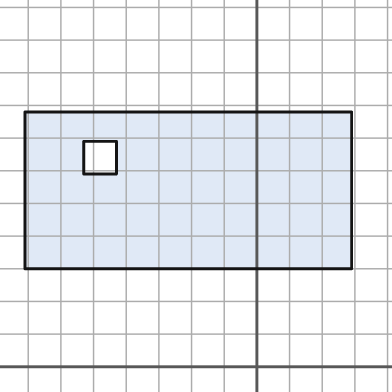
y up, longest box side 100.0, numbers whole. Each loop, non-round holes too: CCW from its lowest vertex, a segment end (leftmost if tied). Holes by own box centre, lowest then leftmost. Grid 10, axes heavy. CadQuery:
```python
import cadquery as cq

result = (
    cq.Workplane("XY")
    .moveTo(-71.0, 30.0)
    .lineTo(29.0, 30.0)
    .lineTo(29.0, 78.0)
    .lineTo(-71.0, 78.0)
    .close()
    .moveTo(-53.0, 59.0)
    .lineTo(-43.0, 59.0)
    .lineTo(-43.0, 69.0)
    .lineTo(-53.0, 69.0)
    .close()
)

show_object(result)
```